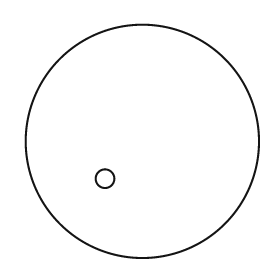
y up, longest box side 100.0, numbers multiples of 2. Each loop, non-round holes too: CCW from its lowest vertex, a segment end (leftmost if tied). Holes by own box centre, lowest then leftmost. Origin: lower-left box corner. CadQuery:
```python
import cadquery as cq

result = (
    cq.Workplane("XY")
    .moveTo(50.0, 50.0)
    .circle(50.0)
    .moveTo(34.0, 34.0)
    .circle(4.0)
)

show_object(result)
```